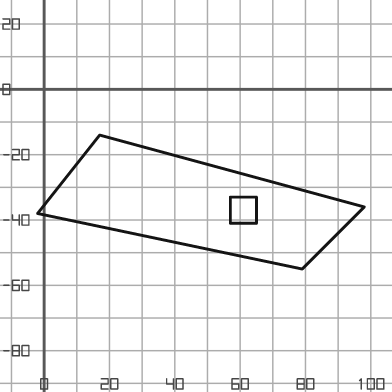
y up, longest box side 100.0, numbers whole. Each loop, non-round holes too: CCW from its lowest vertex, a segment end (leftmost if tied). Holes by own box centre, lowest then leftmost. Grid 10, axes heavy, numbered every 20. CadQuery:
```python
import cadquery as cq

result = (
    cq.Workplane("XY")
    .moveTo(79.0, -55.0)
    .lineTo(98.0, -36.0)
    .lineTo(17.0, -14.0)
    .lineTo(-2.0, -38.0)
    .close()
    .moveTo(57.0, -41.0)
    .lineTo(65.0, -41.0)
    .lineTo(65.0, -33.0)
    .lineTo(57.0, -33.0)
    .close()
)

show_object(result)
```